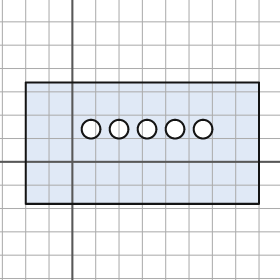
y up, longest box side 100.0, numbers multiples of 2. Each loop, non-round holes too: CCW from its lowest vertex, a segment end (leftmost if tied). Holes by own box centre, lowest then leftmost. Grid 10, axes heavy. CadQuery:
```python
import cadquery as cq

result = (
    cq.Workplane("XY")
    .moveTo(-20.0, -18.0)
    .lineTo(80.0, -18.0)
    .lineTo(80.0, 34.0)
    .lineTo(-20.0, 34.0)
    .close()
    .moveTo(8.0, 14.0)
    .circle(4.0)
    .moveTo(20.0, 14.0)
    .circle(4.0)
    .moveTo(32.0, 14.0)
    .circle(4.0)
    .moveTo(44.0, 14.0)
    .circle(4.0)
    .moveTo(56.0, 14.0)
    .circle(4.0)
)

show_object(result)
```